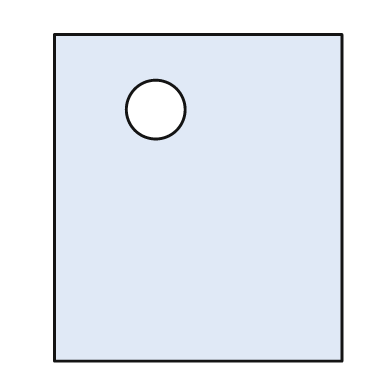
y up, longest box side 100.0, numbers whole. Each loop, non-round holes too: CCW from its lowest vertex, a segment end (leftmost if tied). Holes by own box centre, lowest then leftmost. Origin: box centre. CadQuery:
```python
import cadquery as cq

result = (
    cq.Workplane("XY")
    .moveTo(-44.0, -50.0)
    .lineTo(44.0, -50.0)
    .lineTo(44.0, 50.0)
    .lineTo(-44.0, 50.0)
    .close()
    .moveTo(-13.0, 27.0)
    .circle(9.0)
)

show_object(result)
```